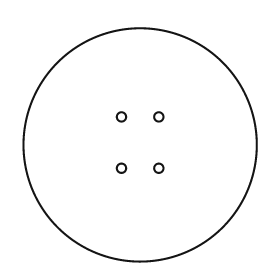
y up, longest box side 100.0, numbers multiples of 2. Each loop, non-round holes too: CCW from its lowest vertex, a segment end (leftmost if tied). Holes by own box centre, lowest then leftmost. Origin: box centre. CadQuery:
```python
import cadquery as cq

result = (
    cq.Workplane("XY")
    .moveTo(0.0, 0.0)
    .circle(50.0)
    .moveTo(-8.0, -10.0)
    .circle(2.0)
    .moveTo(8.0, -10.0)
    .circle(2.0)
    .moveTo(-8.0, 12.0)
    .circle(2.0)
    .moveTo(8.0, 12.0)
    .circle(2.0)
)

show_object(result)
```